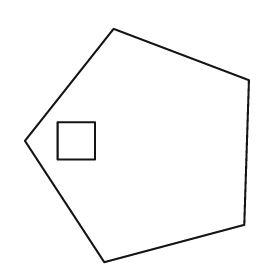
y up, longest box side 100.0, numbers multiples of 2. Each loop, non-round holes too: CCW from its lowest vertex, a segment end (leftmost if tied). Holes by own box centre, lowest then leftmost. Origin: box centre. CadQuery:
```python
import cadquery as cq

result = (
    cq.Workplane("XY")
    .moveTo(-14.0, -50.0)
    .lineTo(46.0, -34.0)
    .lineTo(48.0, 28.0)
    .lineTo(-10.0, 50.0)
    .lineTo(-48.0, 2.0)
    .close()
    .moveTo(-34.0, -6.0)
    .lineTo(-18.0, -6.0)
    .lineTo(-18.0, 10.0)
    .lineTo(-34.0, 10.0)
    .close()
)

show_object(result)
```